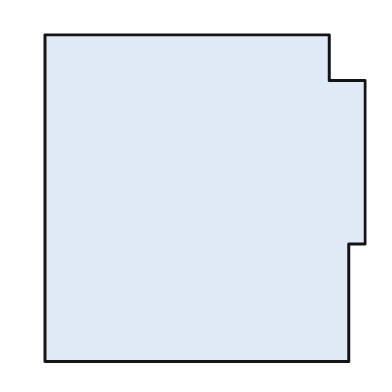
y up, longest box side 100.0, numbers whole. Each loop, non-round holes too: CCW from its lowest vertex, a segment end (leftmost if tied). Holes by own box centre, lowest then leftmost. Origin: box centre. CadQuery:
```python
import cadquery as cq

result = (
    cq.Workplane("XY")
    .moveTo(-49.0, -50.0)
    .lineTo(44.0, -50.0)
    .lineTo(44.0, -14.0)
    .lineTo(49.0, -14.0)
    .lineTo(49.0, 36.0)
    .lineTo(38.0, 36.0)
    .lineTo(38.0, 50.0)
    .lineTo(-49.0, 50.0)
    .close()
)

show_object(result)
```